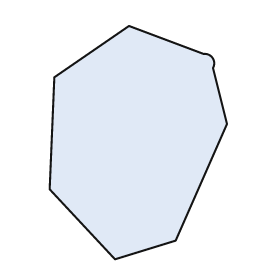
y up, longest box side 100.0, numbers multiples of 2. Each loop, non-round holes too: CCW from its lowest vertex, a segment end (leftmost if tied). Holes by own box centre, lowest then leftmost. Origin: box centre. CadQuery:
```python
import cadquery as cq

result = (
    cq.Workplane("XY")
    .moveTo(-10.0, -50.0)
    .lineTo(16.0, -42.0)
    .lineTo(38.0, 8.0)
    .lineTo(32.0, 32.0)
    .threePointArc((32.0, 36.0), (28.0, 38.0))
    .lineTo(-4.0, 50.0)
    .lineTo(-36.0, 28.0)
    .lineTo(-38.0, -20.0)
    .close()
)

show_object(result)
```